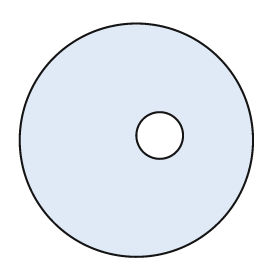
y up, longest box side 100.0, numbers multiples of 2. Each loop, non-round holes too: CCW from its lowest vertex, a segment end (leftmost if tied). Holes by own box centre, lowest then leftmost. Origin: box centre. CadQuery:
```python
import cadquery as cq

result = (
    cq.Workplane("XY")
    .moveTo(0.0, 0.0)
    .circle(50.0)
    .moveTo(10.0, 2.0)
    .circle(10.0)
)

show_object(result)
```